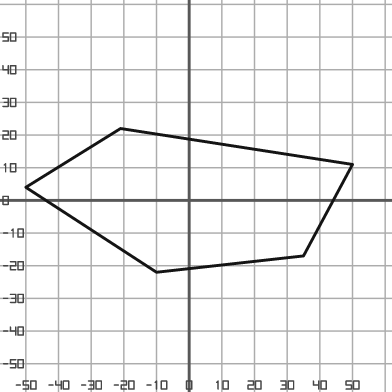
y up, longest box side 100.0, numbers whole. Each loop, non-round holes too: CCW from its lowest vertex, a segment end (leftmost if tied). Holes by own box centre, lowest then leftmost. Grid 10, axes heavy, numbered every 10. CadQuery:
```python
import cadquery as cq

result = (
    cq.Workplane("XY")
    .moveTo(-10.0, -22.0)
    .lineTo(35.0, -17.0)
    .lineTo(50.0, 11.0)
    .lineTo(-21.0, 22.0)
    .lineTo(-50.0, 4.0)
    .close()
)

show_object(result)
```